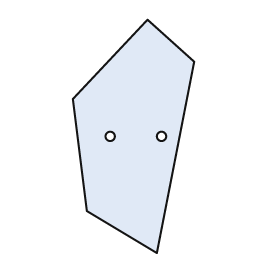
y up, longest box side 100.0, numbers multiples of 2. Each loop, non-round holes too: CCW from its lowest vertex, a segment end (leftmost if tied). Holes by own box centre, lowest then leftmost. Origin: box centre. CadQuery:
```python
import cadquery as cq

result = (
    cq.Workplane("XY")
    .moveTo(10.0, -50.0)
    .lineTo(26.0, 32.0)
    .lineTo(6.0, 50.0)
    .lineTo(-26.0, 16.0)
    .lineTo(-20.0, -32.0)
    .close()
    .moveTo(-10.0, 0.0)
    .circle(2.0)
    .moveTo(12.0, 0.0)
    .circle(2.0)
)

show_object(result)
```